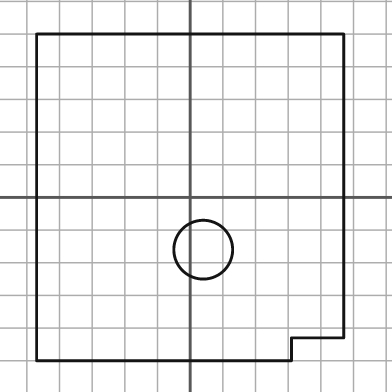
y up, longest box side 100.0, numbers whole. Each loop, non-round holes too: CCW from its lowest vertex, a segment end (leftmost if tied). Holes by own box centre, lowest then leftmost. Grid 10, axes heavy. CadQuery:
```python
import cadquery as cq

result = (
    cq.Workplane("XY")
    .moveTo(-47.0, -50.0)
    .lineTo(31.0, -50.0)
    .lineTo(31.0, -43.0)
    .lineTo(47.0, -43.0)
    .lineTo(47.0, 50.0)
    .lineTo(-47.0, 50.0)
    .close()
    .moveTo(4.0, -16.0)
    .circle(9.0)
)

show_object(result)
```